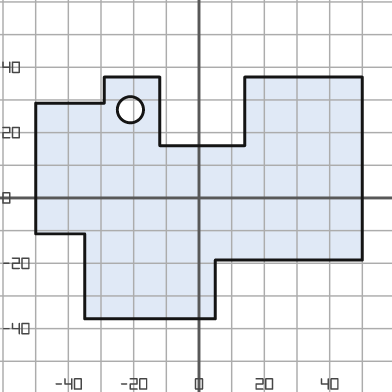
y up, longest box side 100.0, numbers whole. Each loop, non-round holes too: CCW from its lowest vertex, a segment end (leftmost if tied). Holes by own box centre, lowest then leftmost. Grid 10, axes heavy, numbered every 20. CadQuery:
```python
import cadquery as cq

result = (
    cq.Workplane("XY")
    .moveTo(-35.0, -37.0)
    .lineTo(5.0, -37.0)
    .lineTo(5.0, -19.0)
    .lineTo(50.0, -19.0)
    .lineTo(50.0, 37.0)
    .lineTo(14.0, 37.0)
    .lineTo(14.0, 16.0)
    .lineTo(-12.0, 16.0)
    .lineTo(-12.0, 37.0)
    .lineTo(-29.0, 37.0)
    .lineTo(-29.0, 29.0)
    .lineTo(-50.0, 29.0)
    .lineTo(-50.0, -11.0)
    .lineTo(-35.0, -11.0)
    .close()
    .moveTo(-21.0, 27.0)
    .circle(4.0)
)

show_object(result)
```